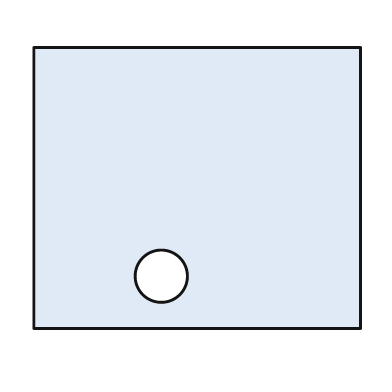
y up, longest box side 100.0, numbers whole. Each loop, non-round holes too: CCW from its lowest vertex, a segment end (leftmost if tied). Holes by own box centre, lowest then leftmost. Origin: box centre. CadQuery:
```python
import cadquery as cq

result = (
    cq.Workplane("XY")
    .moveTo(-50.0, -43.0)
    .lineTo(50.0, -43.0)
    .lineTo(50.0, 43.0)
    .lineTo(-50.0, 43.0)
    .close()
    .moveTo(-11.0, -27.0)
    .circle(8.0)
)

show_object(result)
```